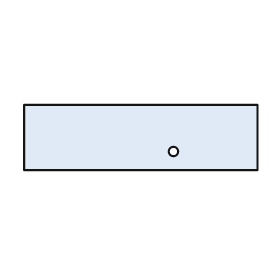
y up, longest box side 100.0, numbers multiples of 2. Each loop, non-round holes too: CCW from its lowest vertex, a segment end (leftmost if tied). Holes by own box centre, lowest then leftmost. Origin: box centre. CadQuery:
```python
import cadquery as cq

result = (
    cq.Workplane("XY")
    .moveTo(-50.0, -14.0)
    .lineTo(50.0, -14.0)
    .lineTo(50.0, 14.0)
    .lineTo(-50.0, 14.0)
    .close()
    .moveTo(14.0, -6.0)
    .circle(2.0)
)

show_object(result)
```